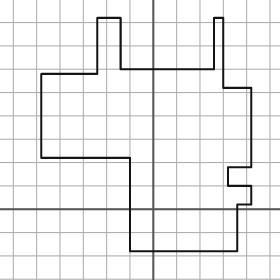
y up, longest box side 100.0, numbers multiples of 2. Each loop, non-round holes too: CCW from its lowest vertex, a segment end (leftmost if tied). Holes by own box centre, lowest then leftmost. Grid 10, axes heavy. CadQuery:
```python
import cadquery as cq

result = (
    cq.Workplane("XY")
    .moveTo(-10.0, -18.0)
    .lineTo(36.0, -18.0)
    .lineTo(36.0, 2.0)
    .lineTo(42.0, 2.0)
    .lineTo(42.0, 10.0)
    .lineTo(32.0, 10.0)
    .lineTo(32.0, 18.0)
    .lineTo(42.0, 18.0)
    .lineTo(42.0, 52.0)
    .lineTo(30.0, 52.0)
    .lineTo(30.0, 82.0)
    .lineTo(26.0, 82.0)
    .lineTo(26.0, 60.0)
    .lineTo(-14.0, 60.0)
    .lineTo(-14.0, 82.0)
    .lineTo(-24.0, 82.0)
    .lineTo(-24.0, 58.0)
    .lineTo(-48.0, 58.0)
    .lineTo(-48.0, 22.0)
    .lineTo(-10.0, 22.0)
    .close()
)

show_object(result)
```